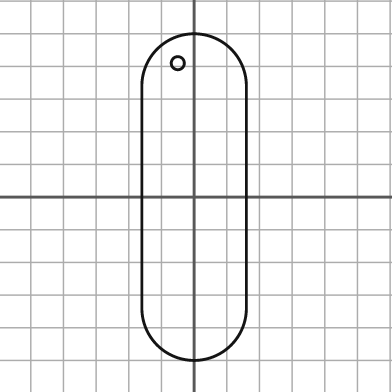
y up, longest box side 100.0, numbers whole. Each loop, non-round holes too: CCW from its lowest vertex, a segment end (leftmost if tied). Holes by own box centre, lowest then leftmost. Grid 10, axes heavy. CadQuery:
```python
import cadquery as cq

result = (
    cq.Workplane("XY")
    .moveTo(-16.0, -34.0)
    .threePointArc((0.0, -50.0), (16.0, -34.0))
    .lineTo(16.0, 34.0)
    .threePointArc((0.0, 50.0), (-16.0, 34.0))
    .close()
    .moveTo(-5.0, 41.0)
    .circle(2.0)
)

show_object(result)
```